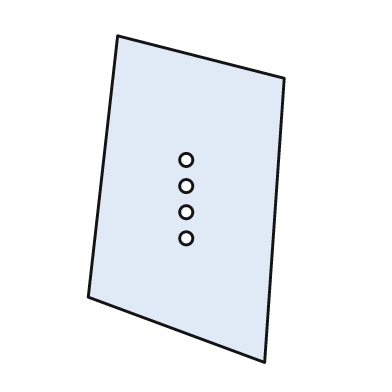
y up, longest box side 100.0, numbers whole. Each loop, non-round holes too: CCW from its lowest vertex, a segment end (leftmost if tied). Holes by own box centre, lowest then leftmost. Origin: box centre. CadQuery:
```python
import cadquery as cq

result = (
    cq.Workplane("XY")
    .moveTo(24.0, -50.0)
    .lineTo(30.0, 37.0)
    .lineTo(-21.0, 50.0)
    .lineTo(-30.0, -30.0)
    .close()
    .moveTo(0.0, -12.0)
    .circle(2.0)
    .moveTo(0.0, -4.0)
    .circle(2.0)
    .moveTo(0.0, 4.0)
    .circle(2.0)
    .moveTo(0.0, 12.0)
    .circle(2.0)
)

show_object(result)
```